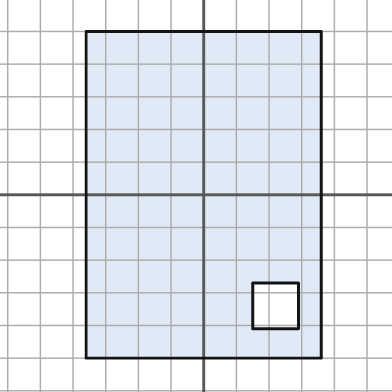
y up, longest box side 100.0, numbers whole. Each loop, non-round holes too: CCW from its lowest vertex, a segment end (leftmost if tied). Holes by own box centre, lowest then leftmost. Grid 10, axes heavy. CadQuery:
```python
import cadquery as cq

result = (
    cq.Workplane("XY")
    .moveTo(-36.0, -50.0)
    .lineTo(36.0, -50.0)
    .lineTo(36.0, 50.0)
    .lineTo(-36.0, 50.0)
    .close()
    .moveTo(15.0, -41.0)
    .lineTo(29.0, -41.0)
    .lineTo(29.0, -27.0)
    .lineTo(15.0, -27.0)
    .close()
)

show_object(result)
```